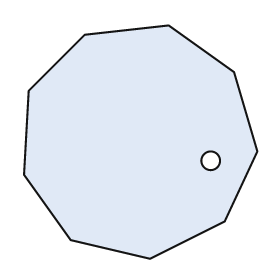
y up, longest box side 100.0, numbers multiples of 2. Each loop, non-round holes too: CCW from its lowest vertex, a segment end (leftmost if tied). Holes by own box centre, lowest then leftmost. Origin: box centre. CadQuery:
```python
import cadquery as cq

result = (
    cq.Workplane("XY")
    .moveTo(4.0, -50.0)
    .lineTo(36.0, -34.0)
    .lineTo(50.0, -4.0)
    .lineTo(40.0, 30.0)
    .lineTo(12.0, 50.0)
    .lineTo(-24.0, 46.0)
    .lineTo(-48.0, 22.0)
    .lineTo(-50.0, -14.0)
    .lineTo(-30.0, -42.0)
    .close()
    .moveTo(30.0, -8.0)
    .circle(4.0)
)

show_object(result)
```